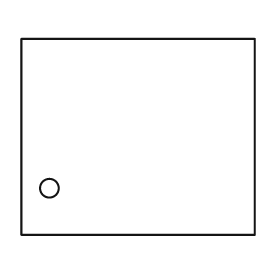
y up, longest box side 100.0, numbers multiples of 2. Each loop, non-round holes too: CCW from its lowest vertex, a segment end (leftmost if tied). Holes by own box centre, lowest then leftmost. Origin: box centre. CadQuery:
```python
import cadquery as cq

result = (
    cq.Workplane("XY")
    .moveTo(-50.0, -42.0)
    .lineTo(50.0, -42.0)
    .lineTo(50.0, 42.0)
    .lineTo(-50.0, 42.0)
    .close()
    .moveTo(-38.0, -22.0)
    .circle(4.0)
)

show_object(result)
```